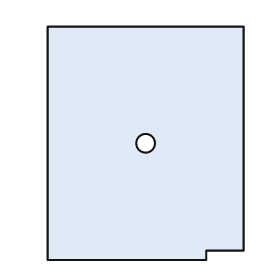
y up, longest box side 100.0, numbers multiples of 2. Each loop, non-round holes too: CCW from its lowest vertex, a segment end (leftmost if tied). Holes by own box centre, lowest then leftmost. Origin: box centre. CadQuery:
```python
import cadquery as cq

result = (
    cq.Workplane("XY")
    .moveTo(-42.0, -50.0)
    .lineTo(26.0, -50.0)
    .lineTo(26.0, -46.0)
    .lineTo(42.0, -46.0)
    .lineTo(42.0, 50.0)
    .lineTo(-42.0, 50.0)
    .close()
    .moveTo(0.0, 0.0)
    .circle(4.0)
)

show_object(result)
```